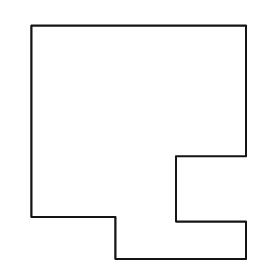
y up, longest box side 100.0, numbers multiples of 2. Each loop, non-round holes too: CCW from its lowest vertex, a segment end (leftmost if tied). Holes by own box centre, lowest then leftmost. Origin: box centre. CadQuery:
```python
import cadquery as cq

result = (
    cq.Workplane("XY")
    .moveTo(-10.0, -50.0)
    .lineTo(46.0, -50.0)
    .lineTo(46.0, -34.0)
    .lineTo(16.0, -34.0)
    .lineTo(16.0, -6.0)
    .lineTo(46.0, -6.0)
    .lineTo(46.0, 50.0)
    .lineTo(-46.0, 50.0)
    .lineTo(-46.0, -32.0)
    .lineTo(-10.0, -32.0)
    .close()
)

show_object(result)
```